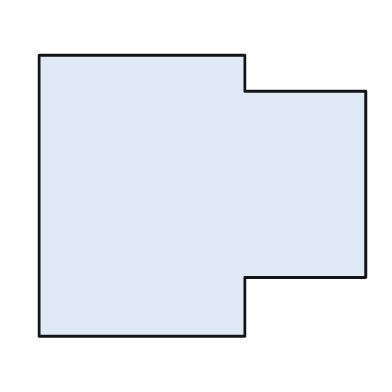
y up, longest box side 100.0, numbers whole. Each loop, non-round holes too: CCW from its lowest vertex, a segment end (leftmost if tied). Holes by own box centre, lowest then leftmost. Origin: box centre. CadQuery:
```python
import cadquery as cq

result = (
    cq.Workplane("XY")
    .moveTo(-50.0, -43.0)
    .lineTo(13.0, -43.0)
    .lineTo(13.0, -25.0)
    .lineTo(50.0, -25.0)
    .lineTo(50.0, 32.0)
    .lineTo(13.0, 32.0)
    .lineTo(13.0, 43.0)
    .lineTo(-50.0, 43.0)
    .close()
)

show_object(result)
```